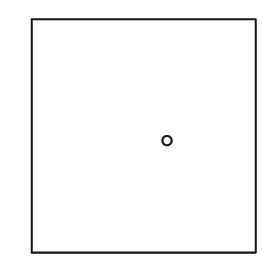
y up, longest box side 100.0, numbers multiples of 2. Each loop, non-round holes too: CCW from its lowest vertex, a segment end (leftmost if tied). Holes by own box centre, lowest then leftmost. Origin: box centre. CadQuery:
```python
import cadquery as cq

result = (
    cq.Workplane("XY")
    .moveTo(-48.0, -50.0)
    .lineTo(48.0, -50.0)
    .lineTo(48.0, 50.0)
    .lineTo(-48.0, 50.0)
    .close()
    .moveTo(10.0, -2.0)
    .circle(2.0)
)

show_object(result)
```